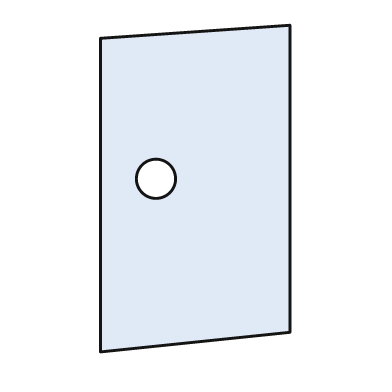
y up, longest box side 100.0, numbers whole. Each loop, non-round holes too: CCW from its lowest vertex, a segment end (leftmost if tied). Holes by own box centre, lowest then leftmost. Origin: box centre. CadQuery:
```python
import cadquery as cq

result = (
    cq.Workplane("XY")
    .moveTo(-29.0, -50.0)
    .lineTo(29.0, -44.0)
    .lineTo(29.0, 50.0)
    .lineTo(-29.0, 46.0)
    .close()
    .moveTo(-12.0, 3.0)
    .circle(6.0)
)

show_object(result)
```